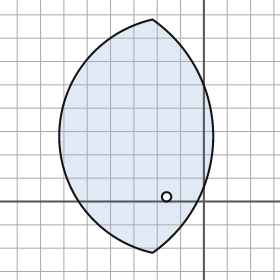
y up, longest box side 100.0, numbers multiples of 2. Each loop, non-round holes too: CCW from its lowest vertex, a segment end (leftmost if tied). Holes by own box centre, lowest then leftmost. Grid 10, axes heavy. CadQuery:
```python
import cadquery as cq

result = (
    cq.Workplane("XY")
    .moveTo(-22.0, -22.0)
    .threePointArc((4.0, 28.0), (-22.0, 78.0))
    .threePointArc((-62.0, 28.0), (-22.0, -22.0))
    .close()
    .moveTo(-16.0, 2.0)
    .circle(2.0)
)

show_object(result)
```